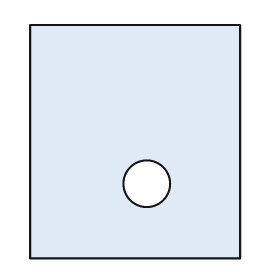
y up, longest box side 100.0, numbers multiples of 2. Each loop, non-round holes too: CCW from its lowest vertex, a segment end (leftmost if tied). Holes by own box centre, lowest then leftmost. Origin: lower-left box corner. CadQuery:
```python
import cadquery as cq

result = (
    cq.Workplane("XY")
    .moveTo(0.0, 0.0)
    .lineTo(90.0, 0.0)
    .lineTo(90.0, 100.0)
    .lineTo(0.0, 100.0)
    .close()
    .moveTo(50.0, 32.0)
    .circle(10.0)
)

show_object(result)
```